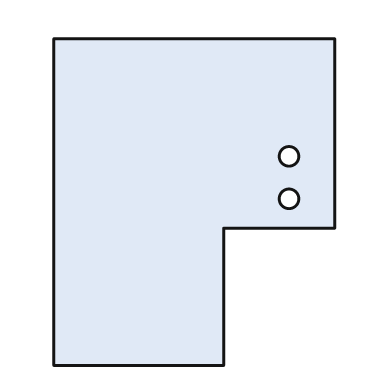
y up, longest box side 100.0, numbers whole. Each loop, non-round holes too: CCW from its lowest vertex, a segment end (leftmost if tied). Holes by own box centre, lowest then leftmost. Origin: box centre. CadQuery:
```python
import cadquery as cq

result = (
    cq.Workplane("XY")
    .moveTo(-43.0, -50.0)
    .lineTo(9.0, -50.0)
    .lineTo(9.0, -8.0)
    .lineTo(43.0, -8.0)
    .lineTo(43.0, 50.0)
    .lineTo(-43.0, 50.0)
    .close()
    .moveTo(29.0, 1.0)
    .circle(3.0)
    .moveTo(29.0, 14.0)
    .circle(3.0)
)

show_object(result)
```